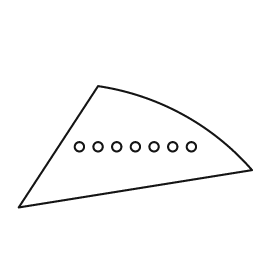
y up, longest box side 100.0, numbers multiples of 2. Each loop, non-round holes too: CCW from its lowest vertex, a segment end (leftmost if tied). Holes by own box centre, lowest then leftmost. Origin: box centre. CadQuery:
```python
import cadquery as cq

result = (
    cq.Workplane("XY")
    .moveTo(-50.0, -26.0)
    .lineTo(50.0, -10.0)
    .threePointArc((20.0, 14.0), (-16.0, 26.0))
    .close()
    .moveTo(-24.0, 0.0)
    .circle(2.0)
    .moveTo(-16.0, 0.0)
    .circle(2.0)
    .moveTo(-8.0, 0.0)
    .circle(2.0)
    .moveTo(0.0, 0.0)
    .circle(2.0)
    .moveTo(8.0, 0.0)
    .circle(2.0)
    .moveTo(16.0, 0.0)
    .circle(2.0)
    .moveTo(24.0, 0.0)
    .circle(2.0)
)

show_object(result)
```